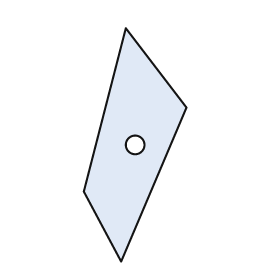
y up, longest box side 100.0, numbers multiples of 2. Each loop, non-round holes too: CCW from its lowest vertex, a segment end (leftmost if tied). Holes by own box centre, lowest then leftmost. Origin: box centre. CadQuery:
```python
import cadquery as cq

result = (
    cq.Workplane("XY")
    .moveTo(-6.0, -50.0)
    .lineTo(22.0, 16.0)
    .lineTo(-4.0, 50.0)
    .lineTo(-22.0, -20.0)
    .close()
    .moveTo(0.0, 0.0)
    .circle(4.0)
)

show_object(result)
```